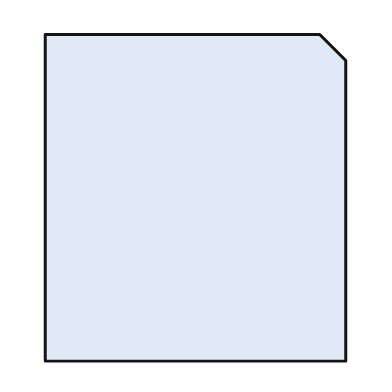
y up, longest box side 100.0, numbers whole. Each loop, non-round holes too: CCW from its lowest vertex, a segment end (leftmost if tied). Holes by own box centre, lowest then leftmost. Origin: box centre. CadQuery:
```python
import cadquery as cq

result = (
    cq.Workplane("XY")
    .moveTo(-46.0, -50.0)
    .lineTo(46.0, -50.0)
    .lineTo(46.0, 42.0)
    .lineTo(38.0, 50.0)
    .lineTo(-46.0, 50.0)
    .close()
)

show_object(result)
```